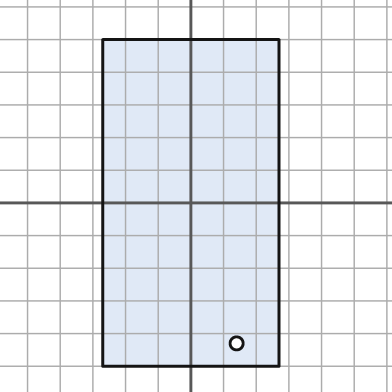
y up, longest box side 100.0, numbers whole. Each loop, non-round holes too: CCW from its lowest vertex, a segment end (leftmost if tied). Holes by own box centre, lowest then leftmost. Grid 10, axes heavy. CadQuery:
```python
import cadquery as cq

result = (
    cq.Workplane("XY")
    .moveTo(-27.0, -50.0)
    .lineTo(27.0, -50.0)
    .lineTo(27.0, 50.0)
    .lineTo(-27.0, 50.0)
    .close()
    .moveTo(14.0, -43.0)
    .circle(2.0)
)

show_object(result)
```